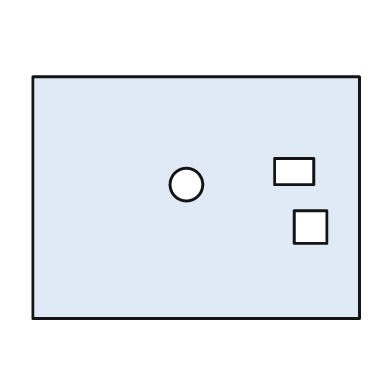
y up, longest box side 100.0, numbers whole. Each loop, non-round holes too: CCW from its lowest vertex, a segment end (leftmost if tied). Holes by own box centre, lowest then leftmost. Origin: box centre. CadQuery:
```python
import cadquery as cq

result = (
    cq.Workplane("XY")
    .moveTo(-50.0, -37.0)
    .lineTo(50.0, -37.0)
    .lineTo(50.0, 37.0)
    .lineTo(-50.0, 37.0)
    .close()
    .moveTo(30.0, -14.0)
    .lineTo(40.0, -14.0)
    .lineTo(40.0, -4.0)
    .lineTo(30.0, -4.0)
    .close()
    .moveTo(-3.0, 4.0)
    .circle(5.0)
    .moveTo(24.0, 4.0)
    .lineTo(36.0, 4.0)
    .lineTo(36.0, 12.0)
    .lineTo(24.0, 12.0)
    .close()
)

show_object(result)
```